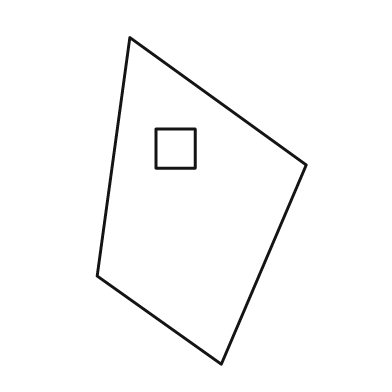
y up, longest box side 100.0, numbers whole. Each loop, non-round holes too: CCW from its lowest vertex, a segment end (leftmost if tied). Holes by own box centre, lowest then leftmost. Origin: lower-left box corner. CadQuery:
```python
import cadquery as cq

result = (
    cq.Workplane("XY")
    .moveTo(38.0, 0.0)
    .lineTo(64.0, 61.0)
    .lineTo(10.0, 100.0)
    .lineTo(0.0, 27.0)
    .close()
    .moveTo(18.0, 60.0)
    .lineTo(30.0, 60.0)
    .lineTo(30.0, 72.0)
    .lineTo(18.0, 72.0)
    .close()
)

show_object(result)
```